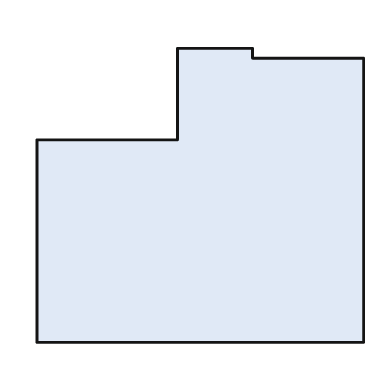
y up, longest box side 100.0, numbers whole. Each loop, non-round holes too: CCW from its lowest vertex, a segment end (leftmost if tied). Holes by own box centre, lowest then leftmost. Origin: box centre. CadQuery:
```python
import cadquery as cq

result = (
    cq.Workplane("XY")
    .moveTo(-50.0, -45.0)
    .lineTo(50.0, -45.0)
    .lineTo(50.0, 42.0)
    .lineTo(16.0, 42.0)
    .lineTo(16.0, 45.0)
    .lineTo(-7.0, 45.0)
    .lineTo(-7.0, 17.0)
    .lineTo(-50.0, 17.0)
    .close()
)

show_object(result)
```